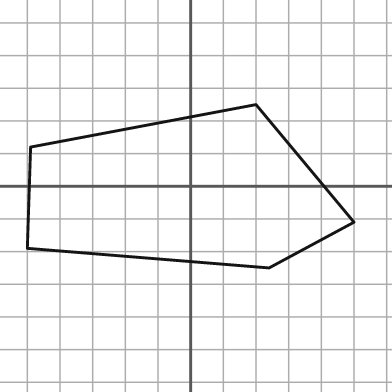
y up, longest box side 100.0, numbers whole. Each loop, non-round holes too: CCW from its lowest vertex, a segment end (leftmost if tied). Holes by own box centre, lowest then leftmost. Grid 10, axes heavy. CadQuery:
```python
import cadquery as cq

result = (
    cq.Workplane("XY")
    .moveTo(24.0, -25.0)
    .lineTo(50.0, -11.0)
    .lineTo(20.0, 25.0)
    .lineTo(-49.0, 12.0)
    .lineTo(-50.0, -19.0)
    .close()
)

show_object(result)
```